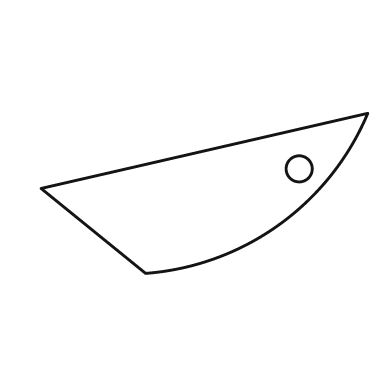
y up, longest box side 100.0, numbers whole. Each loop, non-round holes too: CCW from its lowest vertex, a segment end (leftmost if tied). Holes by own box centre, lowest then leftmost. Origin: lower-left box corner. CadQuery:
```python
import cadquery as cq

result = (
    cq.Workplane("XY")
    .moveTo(32.0, 0.0)
    .threePointArc((73.0, 15.0), (100.0, 49.0))
    .lineTo(0.0, 26.0)
    .close()
    .moveTo(79.0, 32.0)
    .circle(4.0)
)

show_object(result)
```